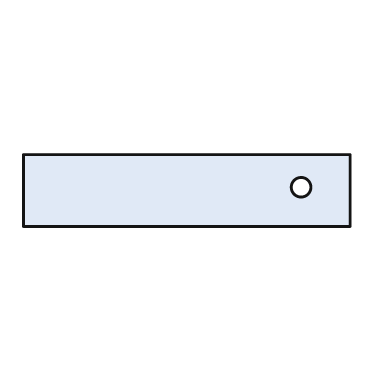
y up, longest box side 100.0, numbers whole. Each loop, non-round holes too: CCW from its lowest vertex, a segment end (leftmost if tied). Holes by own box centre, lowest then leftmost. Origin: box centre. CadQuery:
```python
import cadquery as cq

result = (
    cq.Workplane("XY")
    .moveTo(-50.0, -11.0)
    .lineTo(50.0, -11.0)
    .lineTo(50.0, 11.0)
    .lineTo(-50.0, 11.0)
    .close()
    .moveTo(35.0, 1.0)
    .circle(3.0)
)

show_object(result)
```